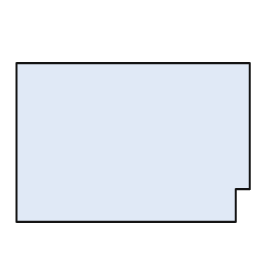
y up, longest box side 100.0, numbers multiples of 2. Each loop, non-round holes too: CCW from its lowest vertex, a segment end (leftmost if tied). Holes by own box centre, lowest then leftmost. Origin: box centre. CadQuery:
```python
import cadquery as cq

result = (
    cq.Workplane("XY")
    .moveTo(-50.0, -34.0)
    .lineTo(44.0, -34.0)
    .lineTo(44.0, -20.0)
    .lineTo(50.0, -20.0)
    .lineTo(50.0, 34.0)
    .lineTo(-50.0, 34.0)
    .close()
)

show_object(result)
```